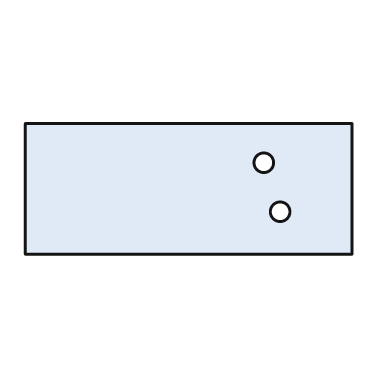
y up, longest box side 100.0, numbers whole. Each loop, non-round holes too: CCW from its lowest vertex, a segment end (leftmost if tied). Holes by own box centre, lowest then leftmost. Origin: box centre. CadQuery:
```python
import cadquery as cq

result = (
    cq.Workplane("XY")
    .moveTo(-50.0, -20.0)
    .lineTo(50.0, -20.0)
    .lineTo(50.0, 20.0)
    .lineTo(-50.0, 20.0)
    .close()
    .moveTo(28.0, -7.0)
    .circle(3.0)
    .moveTo(23.0, 8.0)
    .circle(3.0)
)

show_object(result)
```